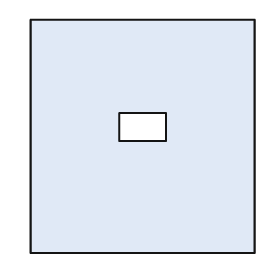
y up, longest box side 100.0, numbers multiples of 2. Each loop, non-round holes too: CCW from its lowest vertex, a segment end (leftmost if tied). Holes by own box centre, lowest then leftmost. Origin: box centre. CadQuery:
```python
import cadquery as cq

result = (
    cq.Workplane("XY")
    .moveTo(-48.0, -50.0)
    .lineTo(48.0, -50.0)
    .lineTo(48.0, 50.0)
    .lineTo(-48.0, 50.0)
    .close()
    .moveTo(-10.0, -2.0)
    .lineTo(10.0, -2.0)
    .lineTo(10.0, 10.0)
    .lineTo(-10.0, 10.0)
    .close()
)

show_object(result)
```